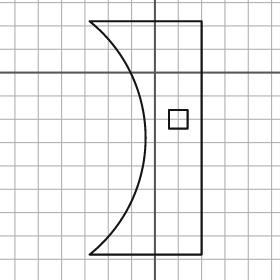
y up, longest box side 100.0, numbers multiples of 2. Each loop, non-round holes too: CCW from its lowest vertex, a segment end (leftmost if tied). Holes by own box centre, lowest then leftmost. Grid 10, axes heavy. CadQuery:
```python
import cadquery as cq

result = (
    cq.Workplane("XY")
    .moveTo(-28.0, -78.0)
    .lineTo(20.0, -78.0)
    .lineTo(20.0, 22.0)
    .lineTo(-28.0, 22.0)
    .threePointArc((-4.0, -28.0), (-28.0, -78.0))
    .close()
    .moveTo(6.0, -24.0)
    .lineTo(14.0, -24.0)
    .lineTo(14.0, -16.0)
    .lineTo(6.0, -16.0)
    .close()
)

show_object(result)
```